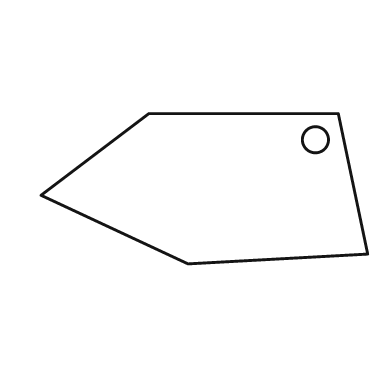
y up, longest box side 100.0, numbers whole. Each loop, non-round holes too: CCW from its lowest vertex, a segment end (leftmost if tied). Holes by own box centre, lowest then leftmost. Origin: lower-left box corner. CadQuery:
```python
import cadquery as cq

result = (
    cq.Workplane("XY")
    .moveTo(45.0, 0.0)
    .lineTo(100.0, 3.0)
    .lineTo(91.0, 46.0)
    .lineTo(33.0, 46.0)
    .lineTo(0.0, 21.0)
    .close()
    .moveTo(84.0, 38.0)
    .circle(4.0)
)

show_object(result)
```